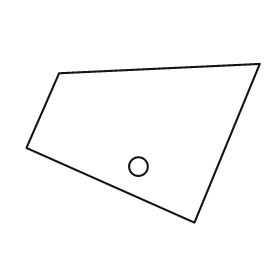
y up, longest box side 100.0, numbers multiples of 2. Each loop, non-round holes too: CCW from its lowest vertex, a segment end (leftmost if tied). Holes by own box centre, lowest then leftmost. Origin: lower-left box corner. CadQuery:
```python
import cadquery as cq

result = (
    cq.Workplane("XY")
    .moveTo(72.0, 0.0)
    .lineTo(100.0, 68.0)
    .lineTo(14.0, 64.0)
    .lineTo(0.0, 32.0)
    .close()
    .moveTo(48.0, 24.0)
    .circle(4.0)
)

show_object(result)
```